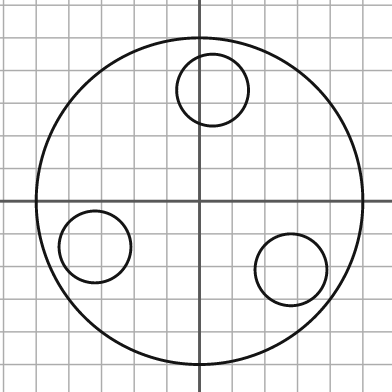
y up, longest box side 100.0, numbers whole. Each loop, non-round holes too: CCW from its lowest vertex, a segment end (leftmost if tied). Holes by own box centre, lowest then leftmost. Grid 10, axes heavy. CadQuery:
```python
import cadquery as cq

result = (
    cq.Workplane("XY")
    .moveTo(0.0, 0.0)
    .circle(50.0)
    .moveTo(28.0, -21.0)
    .circle(11.0)
    .moveTo(-32.0, -14.0)
    .circle(11.0)
    .moveTo(4.0, 34.0)
    .circle(11.0)
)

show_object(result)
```